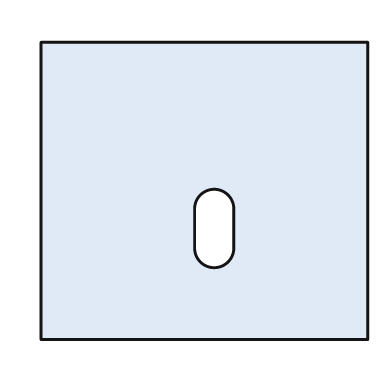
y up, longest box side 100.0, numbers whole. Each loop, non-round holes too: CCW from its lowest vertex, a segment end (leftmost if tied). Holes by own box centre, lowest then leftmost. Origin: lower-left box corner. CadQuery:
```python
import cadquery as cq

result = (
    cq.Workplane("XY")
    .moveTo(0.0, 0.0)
    .lineTo(100.0, 0.0)
    .lineTo(100.0, 91.0)
    .lineTo(0.0, 91.0)
    .close()
    .moveTo(47.0, 28.0)
    .threePointArc((53.0, 22.0), (59.0, 28.0))
    .lineTo(59.0, 40.0)
    .threePointArc((53.0, 46.0), (47.0, 40.0))
    .close()
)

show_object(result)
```